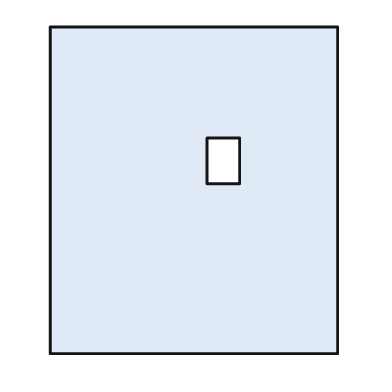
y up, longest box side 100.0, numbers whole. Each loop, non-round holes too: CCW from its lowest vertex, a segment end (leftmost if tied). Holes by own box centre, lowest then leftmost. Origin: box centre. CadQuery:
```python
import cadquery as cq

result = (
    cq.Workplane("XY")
    .moveTo(-44.0, -50.0)
    .lineTo(44.0, -50.0)
    .lineTo(44.0, 50.0)
    .lineTo(-44.0, 50.0)
    .close()
    .moveTo(4.0, 2.0)
    .lineTo(14.0, 2.0)
    .lineTo(14.0, 16.0)
    .lineTo(4.0, 16.0)
    .close()
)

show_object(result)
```